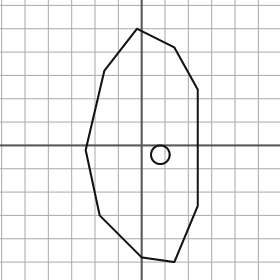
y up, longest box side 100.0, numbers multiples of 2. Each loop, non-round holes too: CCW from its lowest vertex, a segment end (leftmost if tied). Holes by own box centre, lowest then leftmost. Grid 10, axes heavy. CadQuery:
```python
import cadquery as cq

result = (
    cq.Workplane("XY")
    .moveTo(14.0, -50.0)
    .lineTo(24.0, -26.0)
    .lineTo(24.0, 24.0)
    .lineTo(14.0, 42.0)
    .lineTo(-2.0, 50.0)
    .lineTo(-16.0, 32.0)
    .lineTo(-24.0, -2.0)
    .lineTo(-18.0, -30.0)
    .lineTo(0.0, -48.0)
    .close()
    .moveTo(8.0, -4.0)
    .circle(4.0)
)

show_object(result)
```